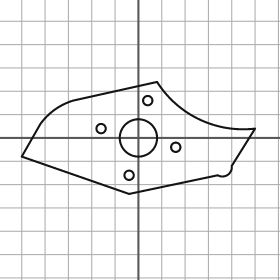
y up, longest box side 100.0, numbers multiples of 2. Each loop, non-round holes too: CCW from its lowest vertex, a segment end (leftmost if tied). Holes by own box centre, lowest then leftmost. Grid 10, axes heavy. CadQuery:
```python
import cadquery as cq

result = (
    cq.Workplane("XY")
    .moveTo(-4.0, -24.0)
    .lineTo(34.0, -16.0)
    .threePointArc((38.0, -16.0), (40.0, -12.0))
    .lineTo(50.0, 4.0)
    .threePointArc((26.0, 8.0), (8.0, 24.0))
    .lineTo(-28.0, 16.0)
    .threePointArc((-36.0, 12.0), (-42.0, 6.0))
    .lineTo(-50.0, -8.0)
    .close()
    .moveTo(-4.0, -16.0)
    .circle(2.0)
    .moveTo(16.0, -4.0)
    .circle(2.0)
    .moveTo(0.0, 0.0)
    .circle(8.0)
    .moveTo(-16.0, 4.0)
    .circle(2.0)
    .moveTo(4.0, 16.0)
    .circle(2.0)
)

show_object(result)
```